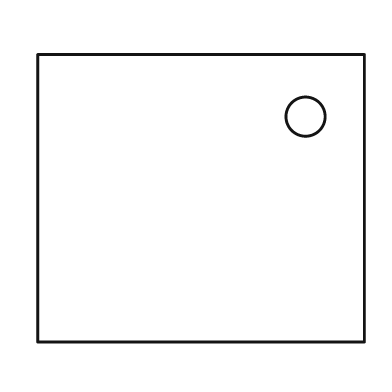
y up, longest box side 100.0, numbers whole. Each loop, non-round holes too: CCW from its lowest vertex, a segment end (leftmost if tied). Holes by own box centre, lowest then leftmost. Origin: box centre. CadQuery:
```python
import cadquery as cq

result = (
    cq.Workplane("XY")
    .moveTo(-50.0, -44.0)
    .lineTo(50.0, -44.0)
    .lineTo(50.0, 44.0)
    .lineTo(-50.0, 44.0)
    .close()
    .moveTo(32.0, 25.0)
    .circle(6.0)
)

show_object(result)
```